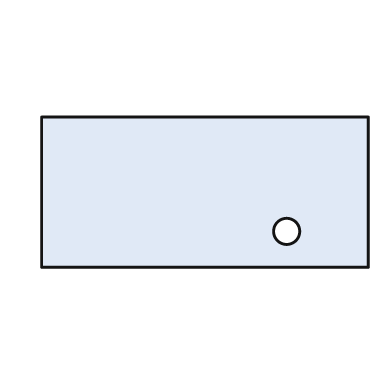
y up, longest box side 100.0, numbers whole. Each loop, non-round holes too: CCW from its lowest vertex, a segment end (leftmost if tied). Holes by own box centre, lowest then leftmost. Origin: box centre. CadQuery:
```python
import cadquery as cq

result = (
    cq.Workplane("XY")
    .moveTo(-50.0, -23.0)
    .lineTo(50.0, -23.0)
    .lineTo(50.0, 23.0)
    .lineTo(-50.0, 23.0)
    .close()
    .moveTo(25.0, -12.0)
    .circle(4.0)
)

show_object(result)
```